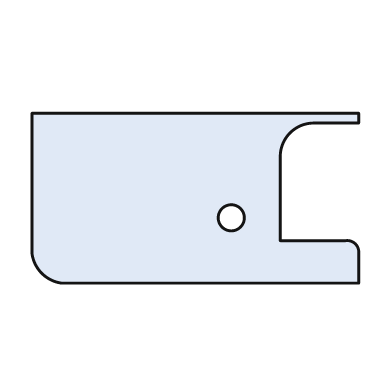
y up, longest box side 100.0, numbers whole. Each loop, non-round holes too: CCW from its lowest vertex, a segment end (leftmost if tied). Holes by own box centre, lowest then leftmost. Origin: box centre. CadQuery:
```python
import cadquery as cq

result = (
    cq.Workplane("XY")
    .moveTo(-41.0, -26.0)
    .lineTo(50.0, -26.0)
    .lineTo(50.0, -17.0)
    .threePointArc((49.0, -14.0), (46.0, -13.0))
    .lineTo(26.0, -13.0)
    .lineTo(26.0, 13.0)
    .threePointArc((29.0, 20.0), (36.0, 23.0))
    .lineTo(50.0, 23.0)
    .lineTo(50.0, 26.0)
    .lineTo(-50.0, 26.0)
    .lineTo(-50.0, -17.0)
    .threePointArc((-47.0, -23.0), (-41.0, -26.0))
    .close()
    .moveTo(11.0, -6.0)
    .circle(4.0)
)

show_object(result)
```